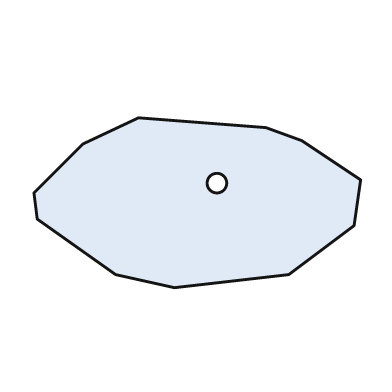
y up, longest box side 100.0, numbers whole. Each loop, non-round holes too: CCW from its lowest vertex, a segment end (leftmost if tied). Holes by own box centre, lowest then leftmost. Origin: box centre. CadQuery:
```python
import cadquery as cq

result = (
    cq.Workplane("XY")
    .moveTo(-7.0, -26.0)
    .lineTo(28.0, -22.0)
    .lineTo(48.0, -7.0)
    .lineTo(50.0, 7.0)
    .lineTo(32.0, 19.0)
    .lineTo(21.0, 23.0)
    .lineTo(-18.0, 26.0)
    .lineTo(-35.0, 18.0)
    .lineTo(-50.0, 3.0)
    .lineTo(-49.0, -5.0)
    .lineTo(-25.0, -22.0)
    .close()
    .moveTo(6.0, 6.0)
    .circle(3.0)
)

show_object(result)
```